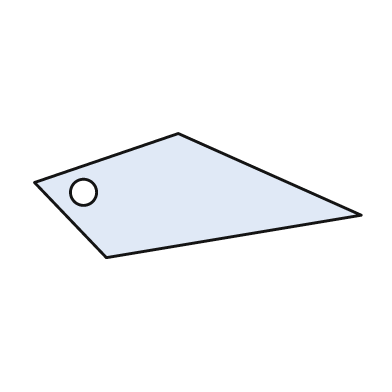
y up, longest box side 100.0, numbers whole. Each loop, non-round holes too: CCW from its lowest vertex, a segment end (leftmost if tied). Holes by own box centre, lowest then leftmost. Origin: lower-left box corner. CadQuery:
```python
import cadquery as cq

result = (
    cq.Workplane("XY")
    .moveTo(22.0, 0.0)
    .lineTo(100.0, 13.0)
    .lineTo(44.0, 38.0)
    .lineTo(0.0, 23.0)
    .close()
    .moveTo(15.0, 20.0)
    .circle(4.0)
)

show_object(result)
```